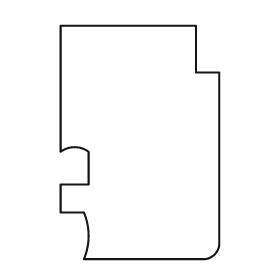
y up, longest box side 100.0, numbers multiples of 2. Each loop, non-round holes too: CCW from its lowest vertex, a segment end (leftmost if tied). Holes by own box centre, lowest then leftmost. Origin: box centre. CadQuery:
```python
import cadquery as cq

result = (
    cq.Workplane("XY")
    .moveTo(-24.0, -50.0)
    .lineTo(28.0, -50.0)
    .threePointArc((32.0, -48.0), (34.0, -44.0))
    .lineTo(34.0, 30.0)
    .lineTo(24.0, 30.0)
    .lineTo(24.0, 50.0)
    .lineTo(-34.0, 50.0)
    .lineTo(-34.0, -4.0)
    .threePointArc((-28.0, -2.0), (-22.0, -4.0))
    .lineTo(-22.0, -18.0)
    .lineTo(-34.0, -18.0)
    .lineTo(-34.0, -30.0)
    .lineTo(-24.0, -30.0)
    .threePointArc((-22.0, -40.0), (-24.0, -50.0))
    .close()
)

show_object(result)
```